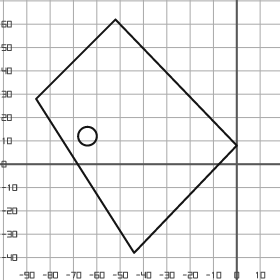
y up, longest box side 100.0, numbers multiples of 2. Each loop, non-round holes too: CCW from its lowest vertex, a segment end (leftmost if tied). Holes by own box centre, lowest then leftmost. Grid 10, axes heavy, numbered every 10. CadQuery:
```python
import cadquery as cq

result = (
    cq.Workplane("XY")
    .moveTo(-44.0, -38.0)
    .lineTo(0.0, 8.0)
    .lineTo(-52.0, 62.0)
    .lineTo(-86.0, 28.0)
    .close()
    .moveTo(-64.0, 12.0)
    .circle(4.0)
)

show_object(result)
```